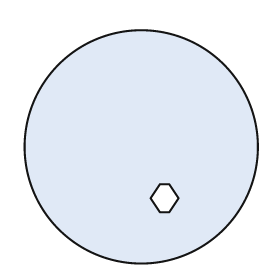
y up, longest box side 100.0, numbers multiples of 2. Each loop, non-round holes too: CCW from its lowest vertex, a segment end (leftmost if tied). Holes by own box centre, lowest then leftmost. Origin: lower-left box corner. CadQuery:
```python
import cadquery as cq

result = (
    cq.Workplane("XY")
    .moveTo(50.0, 50.0)
    .circle(50.0)
    .moveTo(58.0, 22.0)
    .lineTo(62.0, 22.0)
    .lineTo(66.0, 28.0)
    .lineTo(62.0, 34.0)
    .lineTo(58.0, 34.0)
    .lineTo(54.0, 28.0)
    .close()
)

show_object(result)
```